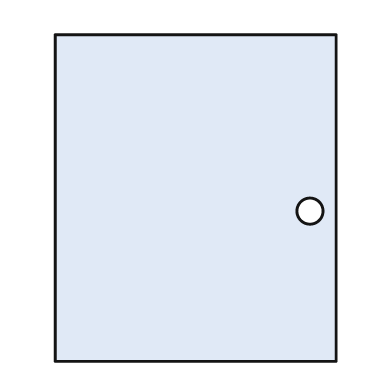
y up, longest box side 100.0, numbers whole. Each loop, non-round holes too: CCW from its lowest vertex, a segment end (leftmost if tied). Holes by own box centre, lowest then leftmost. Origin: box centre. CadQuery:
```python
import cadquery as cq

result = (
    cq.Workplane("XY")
    .moveTo(-43.0, -50.0)
    .lineTo(43.0, -50.0)
    .lineTo(43.0, 50.0)
    .lineTo(-43.0, 50.0)
    .close()
    .moveTo(35.0, -4.0)
    .circle(4.0)
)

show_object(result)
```